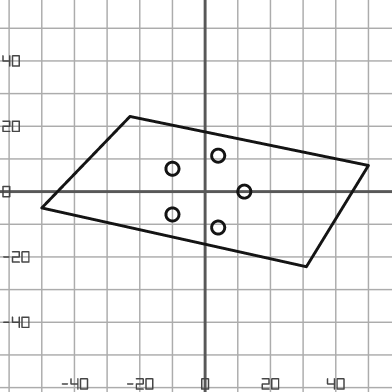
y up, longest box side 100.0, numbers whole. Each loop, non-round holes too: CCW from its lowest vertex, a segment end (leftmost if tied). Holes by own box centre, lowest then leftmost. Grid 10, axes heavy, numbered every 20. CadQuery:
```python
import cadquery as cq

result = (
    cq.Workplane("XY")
    .moveTo(31.0, -23.0)
    .lineTo(50.0, 8.0)
    .lineTo(-23.0, 23.0)
    .lineTo(-50.0, -5.0)
    .close()
    .moveTo(4.0, -11.0)
    .circle(2.0)
    .moveTo(-10.0, -7.0)
    .circle(2.0)
    .moveTo(12.0, 0.0)
    .circle(2.0)
    .moveTo(-10.0, 7.0)
    .circle(2.0)
    .moveTo(4.0, 11.0)
    .circle(2.0)
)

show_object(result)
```